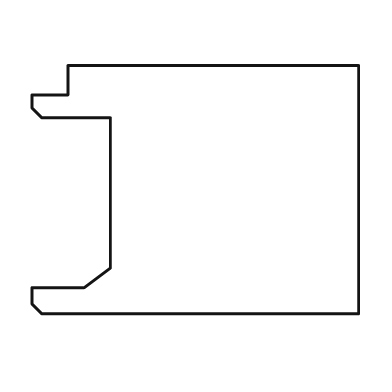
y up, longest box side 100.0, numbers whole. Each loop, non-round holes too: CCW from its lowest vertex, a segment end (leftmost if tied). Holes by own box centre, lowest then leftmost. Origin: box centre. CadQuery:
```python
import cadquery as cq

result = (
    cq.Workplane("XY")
    .moveTo(-47.0, -38.0)
    .lineTo(50.0, -38.0)
    .lineTo(50.0, 38.0)
    .lineTo(-39.0, 38.0)
    .lineTo(-39.0, 29.0)
    .lineTo(-50.0, 29.0)
    .lineTo(-50.0, 25.0)
    .lineTo(-47.0, 22.0)
    .lineTo(-26.0, 22.0)
    .lineTo(-26.0, -24.0)
    .lineTo(-34.0, -30.0)
    .lineTo(-50.0, -30.0)
    .lineTo(-50.0, -35.0)
    .close()
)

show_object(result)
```